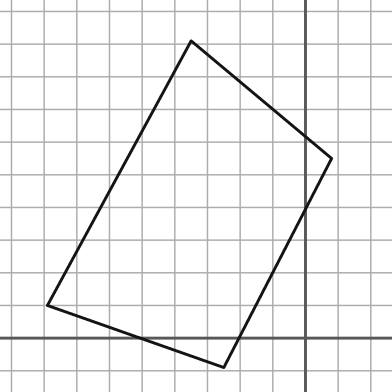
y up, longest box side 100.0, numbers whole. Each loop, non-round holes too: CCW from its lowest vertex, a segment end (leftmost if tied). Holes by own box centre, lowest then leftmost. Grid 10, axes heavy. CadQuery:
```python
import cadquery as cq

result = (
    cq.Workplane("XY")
    .moveTo(-25.0, -9.0)
    .lineTo(8.0, 55.0)
    .lineTo(-35.0, 91.0)
    .lineTo(-79.0, 10.0)
    .close()
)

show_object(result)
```